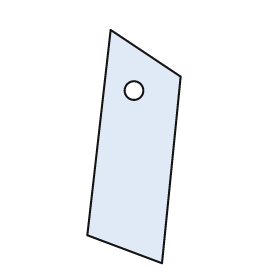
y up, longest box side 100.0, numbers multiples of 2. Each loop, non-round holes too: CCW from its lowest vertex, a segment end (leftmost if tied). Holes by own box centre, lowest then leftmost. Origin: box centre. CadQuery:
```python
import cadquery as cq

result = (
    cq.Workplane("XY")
    .moveTo(12.0, -50.0)
    .lineTo(20.0, 30.0)
    .lineTo(-10.0, 50.0)
    .lineTo(-20.0, -38.0)
    .close()
    .moveTo(0.0, 24.0)
    .circle(4.0)
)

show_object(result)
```